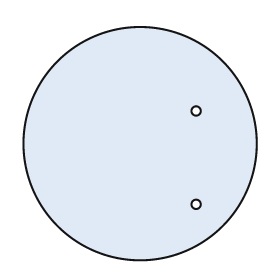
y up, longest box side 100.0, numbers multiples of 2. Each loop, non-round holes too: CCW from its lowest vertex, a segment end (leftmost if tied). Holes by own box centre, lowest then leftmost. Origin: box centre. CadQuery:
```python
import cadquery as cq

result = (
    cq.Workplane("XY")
    .moveTo(0.0, 0.0)
    .circle(50.0)
    .moveTo(24.0, -26.0)
    .circle(2.0)
    .moveTo(24.0, 14.0)
    .circle(2.0)
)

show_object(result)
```